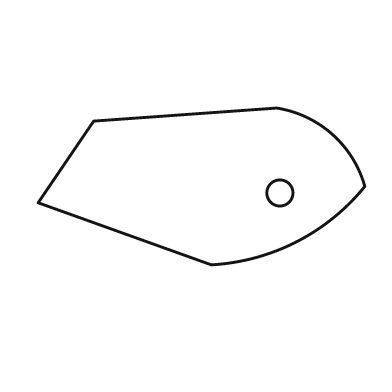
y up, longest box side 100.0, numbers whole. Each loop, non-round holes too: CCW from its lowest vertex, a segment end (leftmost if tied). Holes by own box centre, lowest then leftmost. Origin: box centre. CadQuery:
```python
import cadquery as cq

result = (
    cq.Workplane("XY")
    .moveTo(3.0, -24.0)
    .threePointArc((29.0, -17.0), (50.0, 0.0))
    .threePointArc((40.0, 16.0), (23.0, 24.0))
    .lineTo(-33.0, 20.0)
    .lineTo(-50.0, -5.0)
    .close()
    .moveTo(24.0, -2.0)
    .circle(4.0)
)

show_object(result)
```